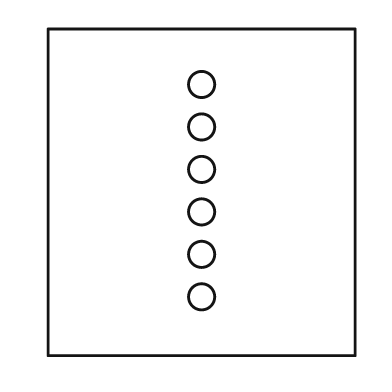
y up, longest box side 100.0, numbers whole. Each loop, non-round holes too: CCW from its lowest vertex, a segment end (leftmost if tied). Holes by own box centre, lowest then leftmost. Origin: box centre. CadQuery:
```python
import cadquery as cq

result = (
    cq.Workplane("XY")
    .moveTo(-47.0, -50.0)
    .lineTo(47.0, -50.0)
    .lineTo(47.0, 50.0)
    .lineTo(-47.0, 50.0)
    .close()
    .moveTo(0.0, -32.0)
    .circle(4.0)
    .moveTo(0.0, -19.0)
    .circle(4.0)
    .moveTo(0.0, -6.0)
    .circle(4.0)
    .moveTo(0.0, 7.0)
    .circle(4.0)
    .moveTo(0.0, 20.0)
    .circle(4.0)
    .moveTo(0.0, 33.0)
    .circle(4.0)
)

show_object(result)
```